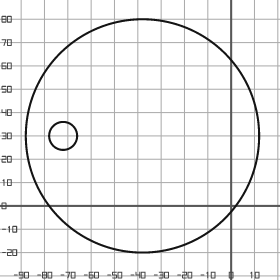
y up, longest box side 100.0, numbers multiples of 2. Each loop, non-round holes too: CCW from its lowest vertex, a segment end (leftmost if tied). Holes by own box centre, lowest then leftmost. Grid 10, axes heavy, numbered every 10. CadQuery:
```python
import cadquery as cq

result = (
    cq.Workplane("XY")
    .moveTo(-38.0, 30.0)
    .circle(50.0)
    .moveTo(-72.0, 30.0)
    .circle(6.0)
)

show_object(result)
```